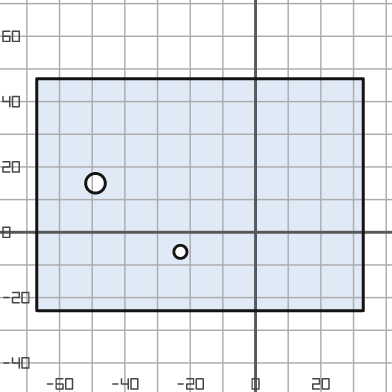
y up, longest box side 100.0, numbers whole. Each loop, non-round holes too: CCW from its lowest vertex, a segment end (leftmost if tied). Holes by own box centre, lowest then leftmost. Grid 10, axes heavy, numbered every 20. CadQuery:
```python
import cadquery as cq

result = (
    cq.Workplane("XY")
    .moveTo(-67.0, -24.0)
    .lineTo(33.0, -24.0)
    .lineTo(33.0, 47.0)
    .lineTo(-67.0, 47.0)
    .close()
    .moveTo(-23.0, -6.0)
    .circle(2.0)
    .moveTo(-49.0, 15.0)
    .circle(3.0)
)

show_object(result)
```